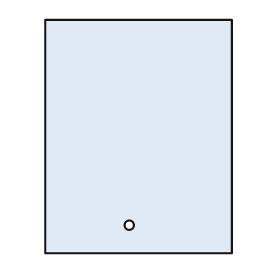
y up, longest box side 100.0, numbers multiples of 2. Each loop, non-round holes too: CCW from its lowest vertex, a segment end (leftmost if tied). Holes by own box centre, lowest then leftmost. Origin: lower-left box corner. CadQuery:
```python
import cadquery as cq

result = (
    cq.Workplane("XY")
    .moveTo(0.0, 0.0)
    .lineTo(80.0, 0.0)
    .lineTo(80.0, 100.0)
    .lineTo(0.0, 100.0)
    .close()
    .moveTo(36.0, 12.0)
    .circle(2.0)
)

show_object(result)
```